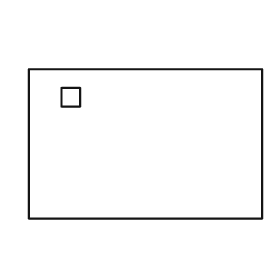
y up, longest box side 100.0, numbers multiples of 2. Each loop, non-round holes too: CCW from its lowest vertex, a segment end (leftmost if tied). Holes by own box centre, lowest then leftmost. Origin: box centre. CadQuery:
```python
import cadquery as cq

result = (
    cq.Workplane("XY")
    .moveTo(-50.0, -32.0)
    .lineTo(50.0, -32.0)
    .lineTo(50.0, 32.0)
    .lineTo(-50.0, 32.0)
    .close()
    .moveTo(-36.0, 16.0)
    .lineTo(-28.0, 16.0)
    .lineTo(-28.0, 24.0)
    .lineTo(-36.0, 24.0)
    .close()
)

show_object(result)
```